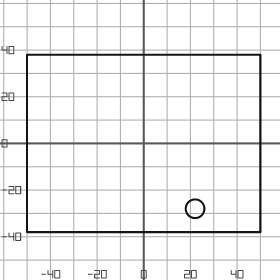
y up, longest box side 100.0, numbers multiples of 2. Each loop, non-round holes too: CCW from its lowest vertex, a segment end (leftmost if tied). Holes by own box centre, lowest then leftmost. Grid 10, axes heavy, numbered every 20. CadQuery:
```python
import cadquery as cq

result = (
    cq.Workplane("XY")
    .moveTo(-50.0, -38.0)
    .lineTo(50.0, -38.0)
    .lineTo(50.0, 38.0)
    .lineTo(-50.0, 38.0)
    .close()
    .moveTo(22.0, -28.0)
    .circle(4.0)
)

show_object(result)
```